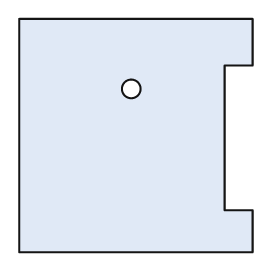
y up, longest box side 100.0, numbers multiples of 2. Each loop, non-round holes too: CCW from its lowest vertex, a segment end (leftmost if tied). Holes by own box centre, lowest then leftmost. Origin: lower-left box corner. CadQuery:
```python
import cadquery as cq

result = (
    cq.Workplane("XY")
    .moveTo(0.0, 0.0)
    .lineTo(100.0, 0.0)
    .lineTo(100.0, 18.0)
    .lineTo(88.0, 18.0)
    .lineTo(88.0, 80.0)
    .lineTo(100.0, 80.0)
    .lineTo(100.0, 100.0)
    .lineTo(0.0, 100.0)
    .close()
    .moveTo(48.0, 70.0)
    .circle(4.0)
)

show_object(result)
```